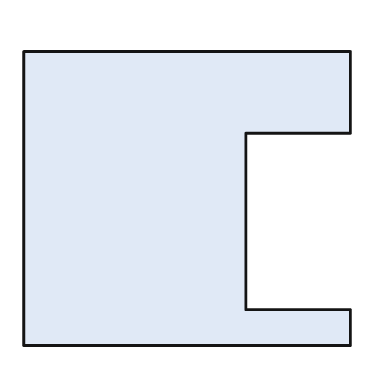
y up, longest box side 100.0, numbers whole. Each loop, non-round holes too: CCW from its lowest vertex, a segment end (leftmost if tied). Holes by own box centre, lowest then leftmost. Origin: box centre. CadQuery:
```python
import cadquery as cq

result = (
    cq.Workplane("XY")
    .moveTo(-50.0, -45.0)
    .lineTo(50.0, -45.0)
    .lineTo(50.0, -34.0)
    .lineTo(18.0, -34.0)
    .lineTo(18.0, 20.0)
    .lineTo(50.0, 20.0)
    .lineTo(50.0, 45.0)
    .lineTo(-50.0, 45.0)
    .close()
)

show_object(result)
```